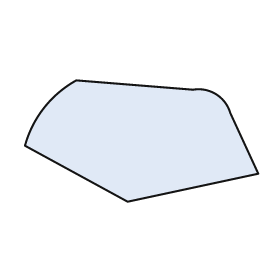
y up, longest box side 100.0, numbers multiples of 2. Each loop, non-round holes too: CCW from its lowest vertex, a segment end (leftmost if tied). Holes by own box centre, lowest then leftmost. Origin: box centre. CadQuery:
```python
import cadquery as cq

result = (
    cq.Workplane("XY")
    .moveTo(-6.0, -26.0)
    .lineTo(50.0, -14.0)
    .lineTo(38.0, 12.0)
    .threePointArc((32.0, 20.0), (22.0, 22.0))
    .lineTo(-28.0, 26.0)
    .threePointArc((-42.0, 14.0), (-50.0, -2.0))
    .close()
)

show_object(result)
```